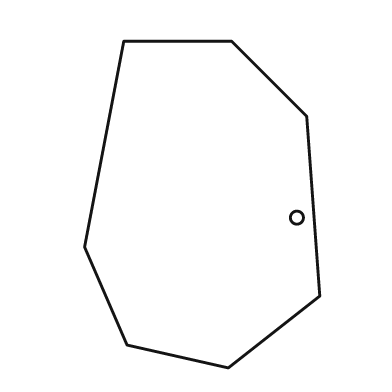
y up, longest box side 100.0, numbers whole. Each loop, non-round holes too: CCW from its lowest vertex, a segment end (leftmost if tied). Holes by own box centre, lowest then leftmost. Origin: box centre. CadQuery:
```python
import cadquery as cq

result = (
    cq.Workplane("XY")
    .moveTo(8.0, -50.0)
    .lineTo(36.0, -28.0)
    .lineTo(32.0, 27.0)
    .lineTo(9.0, 50.0)
    .lineTo(-24.0, 50.0)
    .lineTo(-36.0, -13.0)
    .lineTo(-23.0, -43.0)
    .close()
    .moveTo(29.0, -4.0)
    .circle(2.0)
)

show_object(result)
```